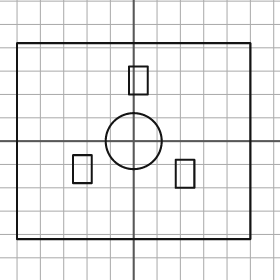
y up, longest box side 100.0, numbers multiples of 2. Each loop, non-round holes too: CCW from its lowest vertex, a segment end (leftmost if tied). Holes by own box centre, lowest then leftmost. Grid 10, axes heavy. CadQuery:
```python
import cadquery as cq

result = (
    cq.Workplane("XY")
    .moveTo(-50.0, -42.0)
    .lineTo(50.0, -42.0)
    .lineTo(50.0, 42.0)
    .lineTo(-50.0, 42.0)
    .close()
    .moveTo(18.0, -20.0)
    .lineTo(26.0, -20.0)
    .lineTo(26.0, -8.0)
    .lineTo(18.0, -8.0)
    .close()
    .moveTo(-26.0, -18.0)
    .lineTo(-18.0, -18.0)
    .lineTo(-18.0, -6.0)
    .lineTo(-26.0, -6.0)
    .close()
    .moveTo(0.0, 0.0)
    .circle(12.0)
    .moveTo(-2.0, 20.0)
    .lineTo(6.0, 20.0)
    .lineTo(6.0, 32.0)
    .lineTo(-2.0, 32.0)
    .close()
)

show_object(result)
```